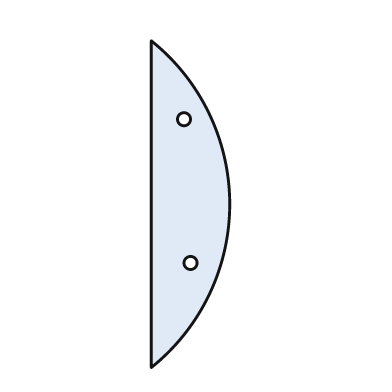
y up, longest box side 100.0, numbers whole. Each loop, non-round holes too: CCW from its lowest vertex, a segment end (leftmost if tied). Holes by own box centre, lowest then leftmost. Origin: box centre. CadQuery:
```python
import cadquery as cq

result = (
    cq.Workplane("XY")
    .moveTo(-12.0, -50.0)
    .threePointArc((12.0, 0.0), (-12.0, 50.0))
    .close()
    .moveTo(0.0, -18.0)
    .circle(2.0)
    .moveTo(-2.0, 26.0)
    .circle(2.0)
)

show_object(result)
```